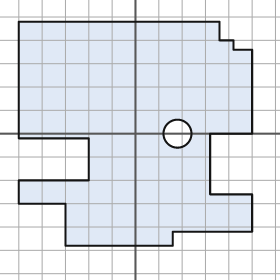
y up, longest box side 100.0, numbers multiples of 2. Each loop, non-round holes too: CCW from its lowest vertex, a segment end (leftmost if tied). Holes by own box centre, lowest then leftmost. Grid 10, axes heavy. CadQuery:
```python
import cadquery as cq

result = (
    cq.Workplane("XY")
    .moveTo(-30.0, -48.0)
    .lineTo(16.0, -48.0)
    .lineTo(16.0, -42.0)
    .lineTo(50.0, -42.0)
    .lineTo(50.0, -26.0)
    .lineTo(32.0, -26.0)
    .lineTo(32.0, 0.0)
    .lineTo(50.0, 0.0)
    .lineTo(50.0, 36.0)
    .lineTo(42.0, 36.0)
    .lineTo(42.0, 40.0)
    .lineTo(36.0, 40.0)
    .lineTo(36.0, 48.0)
    .lineTo(-50.0, 48.0)
    .lineTo(-50.0, -2.0)
    .lineTo(-20.0, -2.0)
    .lineTo(-20.0, -20.0)
    .lineTo(-50.0, -20.0)
    .lineTo(-50.0, -30.0)
    .lineTo(-30.0, -30.0)
    .close()
    .moveTo(18.0, 0.0)
    .circle(6.0)
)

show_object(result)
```